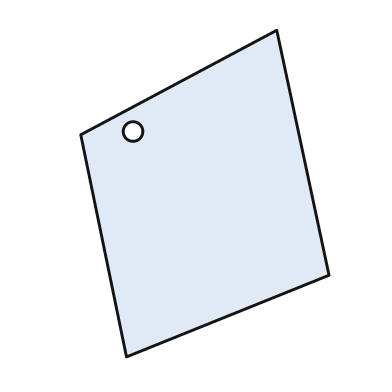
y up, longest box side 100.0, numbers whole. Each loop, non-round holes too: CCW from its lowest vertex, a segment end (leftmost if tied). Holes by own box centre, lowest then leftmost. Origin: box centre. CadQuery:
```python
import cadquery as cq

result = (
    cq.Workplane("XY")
    .moveTo(-24.0, -50.0)
    .lineTo(38.0, -25.0)
    .lineTo(22.0, 50.0)
    .lineTo(-38.0, 18.0)
    .close()
    .moveTo(-22.0, 19.0)
    .circle(3.0)
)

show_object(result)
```